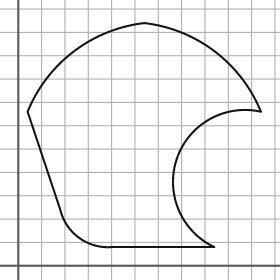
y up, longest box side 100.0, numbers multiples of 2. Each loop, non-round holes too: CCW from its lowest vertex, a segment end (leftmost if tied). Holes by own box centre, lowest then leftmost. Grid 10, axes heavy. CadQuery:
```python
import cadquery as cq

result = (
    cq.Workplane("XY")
    .moveTo(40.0, 8.0)
    .lineTo(84.0, 8.0)
    .threePointArc((68.0, 46.0), (104.0, 66.0))
    .threePointArc((84.0, 92.0), (54.0, 104.0))
    .threePointArc((24.0, 92.0), (4.0, 66.0))
    .lineTo(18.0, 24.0)
    .threePointArc((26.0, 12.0), (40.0, 8.0))
    .close()
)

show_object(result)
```